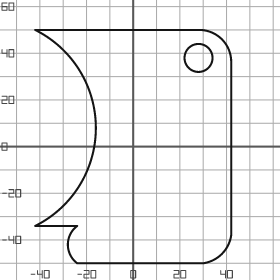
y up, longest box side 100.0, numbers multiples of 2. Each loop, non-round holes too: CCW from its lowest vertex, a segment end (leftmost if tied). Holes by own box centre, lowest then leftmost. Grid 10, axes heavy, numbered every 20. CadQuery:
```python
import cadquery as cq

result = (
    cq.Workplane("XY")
    .moveTo(-24.0, -50.0)
    .lineTo(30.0, -50.0)
    .threePointArc((38.0, -46.0), (42.0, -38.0))
    .lineTo(42.0, 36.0)
    .threePointArc((38.0, 46.0), (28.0, 50.0))
    .lineTo(-42.0, 50.0)
    .threePointArc((-16.0, 8.0), (-42.0, -34.0))
    .lineTo(-24.0, -34.0)
    .threePointArc((-28.0, -42.0), (-24.0, -50.0))
    .close()
    .moveTo(28.0, 38.0)
    .circle(6.0)
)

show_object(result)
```